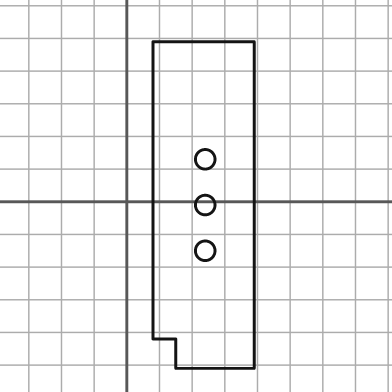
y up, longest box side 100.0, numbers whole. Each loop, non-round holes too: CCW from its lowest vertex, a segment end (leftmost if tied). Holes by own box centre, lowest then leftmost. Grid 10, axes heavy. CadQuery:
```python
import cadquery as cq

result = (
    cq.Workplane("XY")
    .moveTo(15.0, -51.0)
    .lineTo(39.0, -51.0)
    .lineTo(39.0, 49.0)
    .lineTo(8.0, 49.0)
    .lineTo(8.0, -42.0)
    .lineTo(15.0, -42.0)
    .close()
    .moveTo(24.0, -15.0)
    .circle(3.0)
    .moveTo(24.0, -1.0)
    .circle(3.0)
    .moveTo(24.0, 13.0)
    .circle(3.0)
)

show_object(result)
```